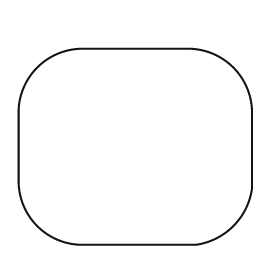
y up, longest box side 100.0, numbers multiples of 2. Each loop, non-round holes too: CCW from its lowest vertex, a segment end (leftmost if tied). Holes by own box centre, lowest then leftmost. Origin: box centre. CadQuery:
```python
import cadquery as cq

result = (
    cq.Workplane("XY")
    .moveTo(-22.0, -42.0)
    .lineTo(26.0, -42.0)
    .threePointArc((42.0, -34.0), (50.0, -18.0))
    .lineTo(50.0, 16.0)
    .threePointArc((42.0, 34.0), (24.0, 42.0))
    .lineTo(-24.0, 42.0)
    .threePointArc((-42.0, 34.0), (-50.0, 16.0))
    .lineTo(-50.0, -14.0)
    .threePointArc((-42.0, -34.0), (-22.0, -42.0))
    .close()
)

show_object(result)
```